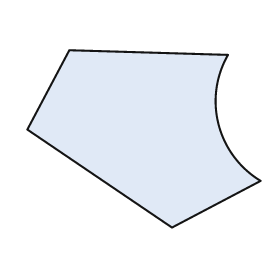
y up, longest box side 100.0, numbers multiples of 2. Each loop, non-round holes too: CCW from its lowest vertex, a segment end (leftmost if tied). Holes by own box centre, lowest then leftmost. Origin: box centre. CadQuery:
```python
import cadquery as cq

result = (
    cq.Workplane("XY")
    .moveTo(12.0, -38.0)
    .lineTo(50.0, -18.0)
    .threePointArc((32.0, 6.0), (36.0, 36.0))
    .lineTo(-32.0, 38.0)
    .lineTo(-50.0, 4.0)
    .close()
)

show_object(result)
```